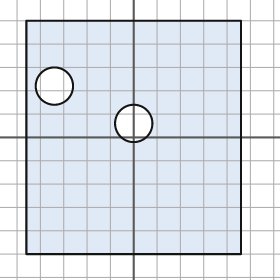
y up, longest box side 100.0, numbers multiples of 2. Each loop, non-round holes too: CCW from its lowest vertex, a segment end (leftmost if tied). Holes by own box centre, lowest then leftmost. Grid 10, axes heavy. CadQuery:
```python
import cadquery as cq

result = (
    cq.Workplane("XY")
    .moveTo(-46.0, -50.0)
    .lineTo(46.0, -50.0)
    .lineTo(46.0, 50.0)
    .lineTo(-46.0, 50.0)
    .close()
    .moveTo(0.0, 6.0)
    .circle(8.0)
    .moveTo(-34.0, 22.0)
    .circle(8.0)
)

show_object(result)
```